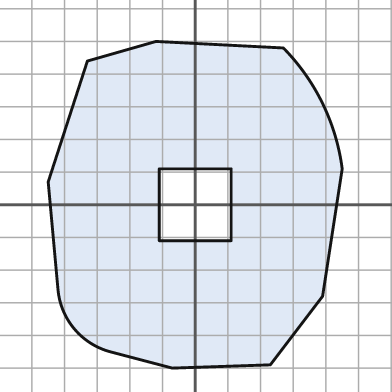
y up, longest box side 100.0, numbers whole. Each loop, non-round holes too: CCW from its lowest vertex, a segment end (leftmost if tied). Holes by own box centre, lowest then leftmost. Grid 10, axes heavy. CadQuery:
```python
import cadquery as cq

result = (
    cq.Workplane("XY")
    .moveTo(-7.0, -50.0)
    .lineTo(23.0, -49.0)
    .lineTo(39.0, -28.0)
    .lineTo(45.0, 11.0)
    .threePointArc((39.0, 31.0), (27.0, 48.0))
    .lineTo(-12.0, 50.0)
    .lineTo(-33.0, 44.0)
    .lineTo(-45.0, 7.0)
    .lineTo(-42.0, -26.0)
    .threePointArc((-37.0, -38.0), (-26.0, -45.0))
    .close()
    .moveTo(-11.0, -11.0)
    .lineTo(11.0, -11.0)
    .lineTo(11.0, 11.0)
    .lineTo(-11.0, 11.0)
    .close()
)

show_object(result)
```